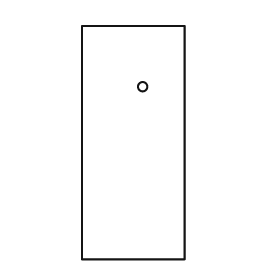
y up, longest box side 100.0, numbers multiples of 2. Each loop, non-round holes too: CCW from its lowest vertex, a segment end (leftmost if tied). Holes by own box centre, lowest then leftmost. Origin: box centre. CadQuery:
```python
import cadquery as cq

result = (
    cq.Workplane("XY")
    .moveTo(-22.0, -50.0)
    .lineTo(22.0, -50.0)
    .lineTo(22.0, 50.0)
    .lineTo(-22.0, 50.0)
    .close()
    .moveTo(4.0, 24.0)
    .circle(2.0)
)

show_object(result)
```